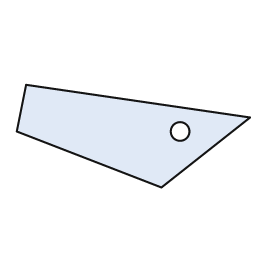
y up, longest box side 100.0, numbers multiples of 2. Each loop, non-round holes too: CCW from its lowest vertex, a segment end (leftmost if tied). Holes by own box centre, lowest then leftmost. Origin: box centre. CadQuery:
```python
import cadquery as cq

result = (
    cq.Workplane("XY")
    .moveTo(12.0, -22.0)
    .lineTo(50.0, 8.0)
    .lineTo(-46.0, 22.0)
    .lineTo(-50.0, 2.0)
    .close()
    .moveTo(20.0, 2.0)
    .circle(4.0)
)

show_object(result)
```